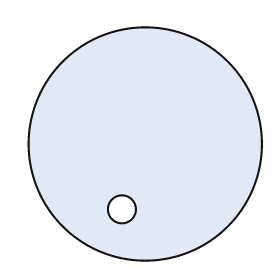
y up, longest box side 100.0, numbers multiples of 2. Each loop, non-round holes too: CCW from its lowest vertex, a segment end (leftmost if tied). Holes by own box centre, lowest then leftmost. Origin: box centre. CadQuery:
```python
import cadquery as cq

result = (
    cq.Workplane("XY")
    .moveTo(0.0, 0.0)
    .circle(50.0)
    .moveTo(-10.0, -28.0)
    .circle(6.0)
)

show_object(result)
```